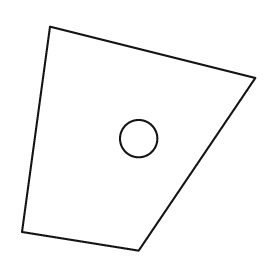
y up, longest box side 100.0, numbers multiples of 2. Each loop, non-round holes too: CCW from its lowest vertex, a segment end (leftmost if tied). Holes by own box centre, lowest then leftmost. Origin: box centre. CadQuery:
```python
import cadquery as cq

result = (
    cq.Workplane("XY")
    .moveTo(0.0, -48.0)
    .lineTo(50.0, 26.0)
    .lineTo(-38.0, 48.0)
    .lineTo(-50.0, -40.0)
    .close()
    .moveTo(0.0, 0.0)
    .circle(8.0)
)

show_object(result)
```